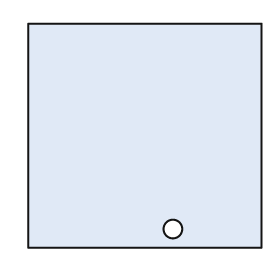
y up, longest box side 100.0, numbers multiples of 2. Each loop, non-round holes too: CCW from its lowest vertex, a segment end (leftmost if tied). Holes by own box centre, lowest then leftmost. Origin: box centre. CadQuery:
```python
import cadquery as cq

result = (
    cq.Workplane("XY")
    .moveTo(-50.0, -48.0)
    .lineTo(50.0, -48.0)
    .lineTo(50.0, 48.0)
    .lineTo(-50.0, 48.0)
    .close()
    .moveTo(12.0, -40.0)
    .circle(4.0)
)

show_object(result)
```